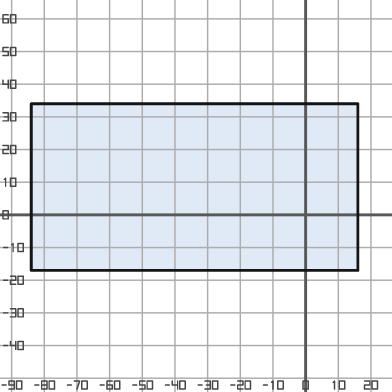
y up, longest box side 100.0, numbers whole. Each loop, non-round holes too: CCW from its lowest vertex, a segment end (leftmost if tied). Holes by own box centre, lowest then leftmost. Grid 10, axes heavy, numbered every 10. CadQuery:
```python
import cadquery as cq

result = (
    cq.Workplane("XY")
    .moveTo(-84.0, -17.0)
    .lineTo(16.0, -17.0)
    .lineTo(16.0, 34.0)
    .lineTo(-84.0, 34.0)
    .close()
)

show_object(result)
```